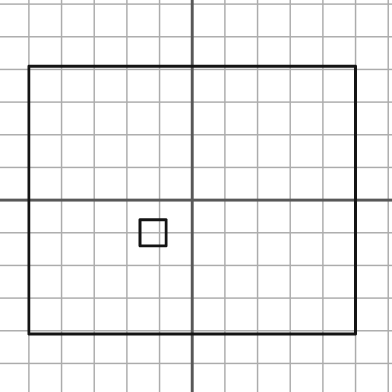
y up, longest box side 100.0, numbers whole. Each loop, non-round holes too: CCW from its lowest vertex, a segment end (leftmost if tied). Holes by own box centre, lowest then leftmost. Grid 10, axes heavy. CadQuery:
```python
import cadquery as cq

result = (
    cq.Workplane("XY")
    .moveTo(-50.0, -41.0)
    .lineTo(50.0, -41.0)
    .lineTo(50.0, 41.0)
    .lineTo(-50.0, 41.0)
    .close()
    .moveTo(-16.0, -14.0)
    .lineTo(-8.0, -14.0)
    .lineTo(-8.0, -6.0)
    .lineTo(-16.0, -6.0)
    .close()
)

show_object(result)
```